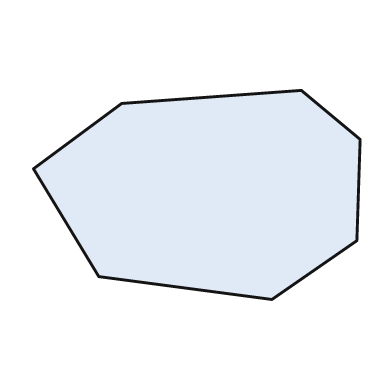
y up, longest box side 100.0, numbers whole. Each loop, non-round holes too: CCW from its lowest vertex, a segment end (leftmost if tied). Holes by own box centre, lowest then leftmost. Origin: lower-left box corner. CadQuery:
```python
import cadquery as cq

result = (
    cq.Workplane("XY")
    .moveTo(73.0, 0.0)
    .lineTo(99.0, 18.0)
    .lineTo(100.0, 49.0)
    .lineTo(82.0, 64.0)
    .lineTo(27.0, 60.0)
    .lineTo(0.0, 40.0)
    .lineTo(20.0, 7.0)
    .close()
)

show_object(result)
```